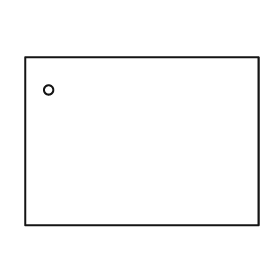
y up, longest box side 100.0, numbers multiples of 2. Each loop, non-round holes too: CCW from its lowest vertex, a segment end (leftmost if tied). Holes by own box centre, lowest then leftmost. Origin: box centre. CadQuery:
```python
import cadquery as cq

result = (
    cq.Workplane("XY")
    .moveTo(-50.0, -36.0)
    .lineTo(50.0, -36.0)
    .lineTo(50.0, 36.0)
    .lineTo(-50.0, 36.0)
    .close()
    .moveTo(-40.0, 22.0)
    .circle(2.0)
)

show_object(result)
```